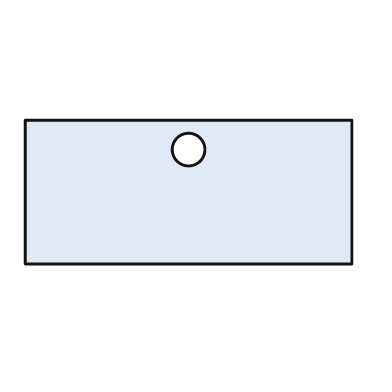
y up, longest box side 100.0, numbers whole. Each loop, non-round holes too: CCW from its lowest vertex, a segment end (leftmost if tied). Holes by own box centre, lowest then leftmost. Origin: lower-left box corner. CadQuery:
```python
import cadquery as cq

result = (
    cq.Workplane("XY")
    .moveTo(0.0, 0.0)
    .lineTo(100.0, 0.0)
    .lineTo(100.0, 44.0)
    .lineTo(0.0, 44.0)
    .close()
    .moveTo(50.0, 35.0)
    .circle(5.0)
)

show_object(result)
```